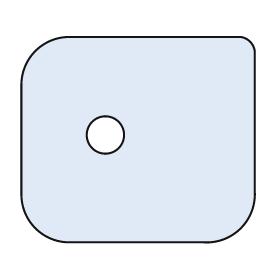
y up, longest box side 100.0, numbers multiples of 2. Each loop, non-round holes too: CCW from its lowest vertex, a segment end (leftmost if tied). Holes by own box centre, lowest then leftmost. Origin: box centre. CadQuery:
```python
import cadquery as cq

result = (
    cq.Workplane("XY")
    .moveTo(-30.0, -44.0)
    .lineTo(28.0, -44.0)
    .threePointArc((44.0, -38.0), (50.0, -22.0))
    .lineTo(50.0, 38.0)
    .threePointArc((48.0, 42.0), (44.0, 44.0))
    .lineTo(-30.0, 44.0)
    .threePointArc((-44.0, 38.0), (-50.0, 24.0))
    .lineTo(-50.0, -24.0)
    .threePointArc((-44.0, -38.0), (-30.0, -44.0))
    .close()
    .moveTo(-14.0, 2.0)
    .circle(8.0)
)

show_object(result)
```